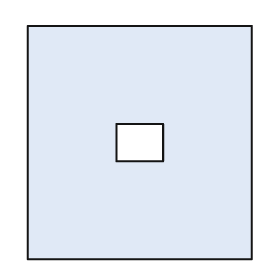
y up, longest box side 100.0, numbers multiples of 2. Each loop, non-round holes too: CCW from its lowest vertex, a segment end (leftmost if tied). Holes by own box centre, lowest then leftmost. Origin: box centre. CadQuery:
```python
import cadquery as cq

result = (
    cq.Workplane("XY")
    .moveTo(-48.0, -50.0)
    .lineTo(48.0, -50.0)
    .lineTo(48.0, 50.0)
    .lineTo(-48.0, 50.0)
    .close()
    .moveTo(-10.0, -8.0)
    .lineTo(10.0, -8.0)
    .lineTo(10.0, 8.0)
    .lineTo(-10.0, 8.0)
    .close()
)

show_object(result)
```